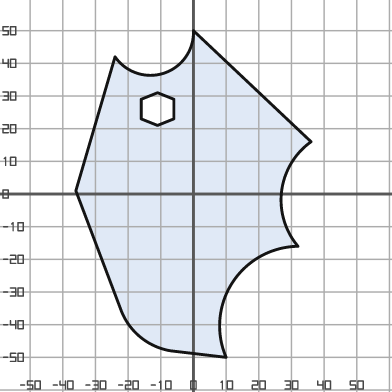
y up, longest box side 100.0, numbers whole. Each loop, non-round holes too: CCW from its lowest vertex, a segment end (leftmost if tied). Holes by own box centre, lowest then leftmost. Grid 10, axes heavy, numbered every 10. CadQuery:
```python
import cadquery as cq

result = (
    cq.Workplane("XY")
    .moveTo(10.0, -50.0)
    .threePointArc((12.0, -27.0), (32.0, -16.0))
    .threePointArc((27.0, 1.0), (36.0, 16.0))
    .lineTo(0.0, 50.0)
    .threePointArc((-9.0, 37.0), (-24.0, 42.0))
    .lineTo(-36.0, 1.0)
    .lineTo(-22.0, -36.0)
    .threePointArc((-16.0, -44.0), (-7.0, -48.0))
    .close()
    .moveTo(-11.0, 21.0)
    .lineTo(-6.0, 23.0)
    .lineTo(-6.0, 29.0)
    .lineTo(-11.0, 31.0)
    .lineTo(-16.0, 29.0)
    .lineTo(-16.0, 23.0)
    .close()
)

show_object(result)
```